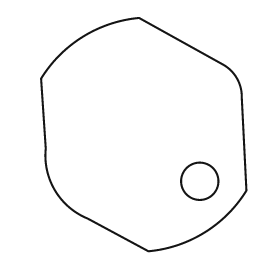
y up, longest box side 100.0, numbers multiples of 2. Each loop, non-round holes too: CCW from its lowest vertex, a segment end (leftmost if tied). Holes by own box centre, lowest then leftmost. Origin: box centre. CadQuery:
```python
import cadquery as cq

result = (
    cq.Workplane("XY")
    .moveTo(2.0, -50.0)
    .threePointArc((26.0, -42.0), (44.0, -24.0))
    .lineTo(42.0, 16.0)
    .threePointArc((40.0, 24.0), (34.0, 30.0))
    .lineTo(-2.0, 50.0)
    .threePointArc((-26.0, 42.0), (-44.0, 24.0))
    .lineTo(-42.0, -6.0)
    .threePointArc((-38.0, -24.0), (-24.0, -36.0))
    .close()
    .moveTo(24.0, -20.0)
    .circle(8.0)
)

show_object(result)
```